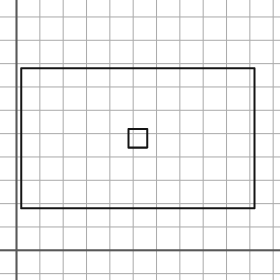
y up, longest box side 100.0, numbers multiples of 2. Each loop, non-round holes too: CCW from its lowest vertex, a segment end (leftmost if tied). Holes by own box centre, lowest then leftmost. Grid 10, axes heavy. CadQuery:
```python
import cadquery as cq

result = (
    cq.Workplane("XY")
    .moveTo(2.0, 18.0)
    .lineTo(102.0, 18.0)
    .lineTo(102.0, 78.0)
    .lineTo(2.0, 78.0)
    .close()
    .moveTo(48.0, 44.0)
    .lineTo(56.0, 44.0)
    .lineTo(56.0, 52.0)
    .lineTo(48.0, 52.0)
    .close()
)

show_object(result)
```